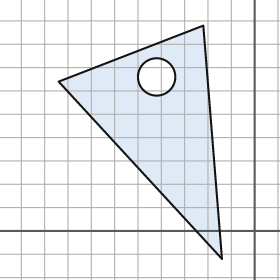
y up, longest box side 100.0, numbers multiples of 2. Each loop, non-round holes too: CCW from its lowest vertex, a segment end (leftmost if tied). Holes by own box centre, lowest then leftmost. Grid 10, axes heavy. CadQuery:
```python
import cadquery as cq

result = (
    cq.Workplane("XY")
    .moveTo(-14.0, -12.0)
    .lineTo(-22.0, 88.0)
    .lineTo(-84.0, 64.0)
    .close()
    .moveTo(-42.0, 66.0)
    .circle(8.0)
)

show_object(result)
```